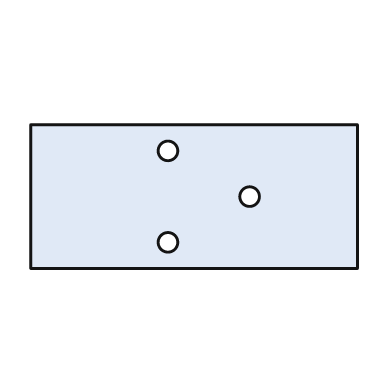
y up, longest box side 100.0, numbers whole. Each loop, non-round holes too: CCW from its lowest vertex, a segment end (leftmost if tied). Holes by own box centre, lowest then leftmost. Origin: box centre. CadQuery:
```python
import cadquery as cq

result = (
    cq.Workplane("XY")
    .moveTo(-50.0, -22.0)
    .lineTo(50.0, -22.0)
    .lineTo(50.0, 22.0)
    .lineTo(-50.0, 22.0)
    .close()
    .moveTo(-8.0, -14.0)
    .circle(3.0)
    .moveTo(17.0, 0.0)
    .circle(3.0)
    .moveTo(-8.0, 14.0)
    .circle(3.0)
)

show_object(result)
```